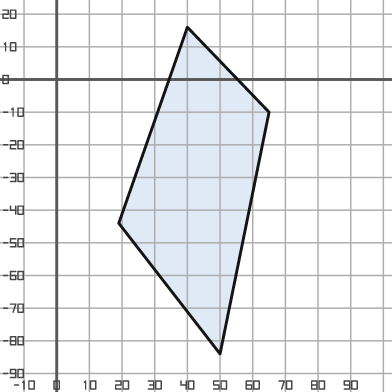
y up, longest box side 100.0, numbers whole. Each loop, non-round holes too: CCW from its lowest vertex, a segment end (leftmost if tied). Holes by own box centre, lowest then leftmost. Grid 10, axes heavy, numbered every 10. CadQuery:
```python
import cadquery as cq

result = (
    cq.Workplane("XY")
    .moveTo(50.0, -84.0)
    .lineTo(65.0, -10.0)
    .lineTo(40.0, 16.0)
    .lineTo(19.0, -44.0)
    .close()
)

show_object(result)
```